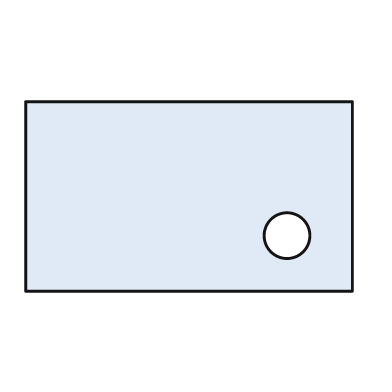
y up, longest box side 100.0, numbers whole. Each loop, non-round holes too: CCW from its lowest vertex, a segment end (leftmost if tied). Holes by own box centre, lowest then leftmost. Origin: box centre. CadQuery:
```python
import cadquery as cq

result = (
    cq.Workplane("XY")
    .moveTo(-50.0, -29.0)
    .lineTo(50.0, -29.0)
    .lineTo(50.0, 29.0)
    .lineTo(-50.0, 29.0)
    .close()
    .moveTo(30.0, -12.0)
    .circle(7.0)
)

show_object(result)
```